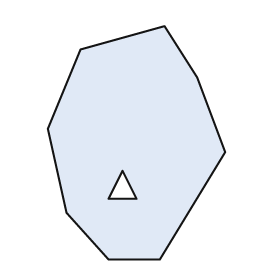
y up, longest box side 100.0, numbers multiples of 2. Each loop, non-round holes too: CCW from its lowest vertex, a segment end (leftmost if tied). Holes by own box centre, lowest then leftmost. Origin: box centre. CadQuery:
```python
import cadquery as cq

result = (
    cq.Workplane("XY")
    .moveTo(-12.0, -50.0)
    .lineTo(10.0, -50.0)
    .lineTo(38.0, -4.0)
    .lineTo(26.0, 28.0)
    .lineTo(12.0, 50.0)
    .lineTo(-24.0, 40.0)
    .lineTo(-38.0, 6.0)
    .lineTo(-30.0, -30.0)
    .close()
    .moveTo(-12.0, -24.0)
    .lineTo(0.0, -24.0)
    .lineTo(-6.0, -12.0)
    .close()
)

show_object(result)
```